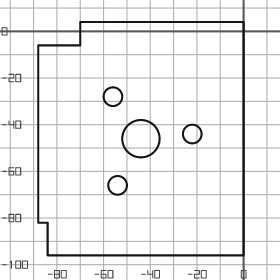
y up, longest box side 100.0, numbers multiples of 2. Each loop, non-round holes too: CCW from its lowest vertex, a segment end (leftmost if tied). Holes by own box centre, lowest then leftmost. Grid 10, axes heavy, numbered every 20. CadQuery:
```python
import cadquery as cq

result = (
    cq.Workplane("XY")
    .moveTo(-84.0, -96.0)
    .lineTo(0.0, -96.0)
    .lineTo(0.0, 4.0)
    .lineTo(-70.0, 4.0)
    .lineTo(-70.0, -6.0)
    .lineTo(-88.0, -6.0)
    .lineTo(-88.0, -82.0)
    .lineTo(-84.0, -82.0)
    .close()
    .moveTo(-54.0, -66.0)
    .circle(4.0)
    .moveTo(-44.0, -46.0)
    .circle(8.0)
    .moveTo(-22.0, -44.0)
    .circle(4.0)
    .moveTo(-56.0, -28.0)
    .circle(4.0)
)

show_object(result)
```